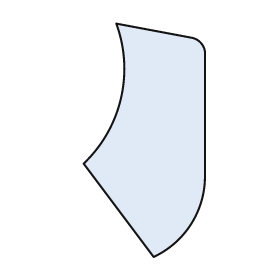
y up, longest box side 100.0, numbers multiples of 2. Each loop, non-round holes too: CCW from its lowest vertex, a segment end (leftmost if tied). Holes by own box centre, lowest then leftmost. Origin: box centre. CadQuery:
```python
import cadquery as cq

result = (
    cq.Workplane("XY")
    .moveTo(4.0, -50.0)
    .threePointArc((20.0, -36.0), (26.0, -16.0))
    .lineTo(26.0, 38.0)
    .threePointArc((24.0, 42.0), (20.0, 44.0))
    .lineTo(-12.0, 50.0)
    .threePointArc((-10.0, 18.0), (-26.0, -10.0))
    .close()
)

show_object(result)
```